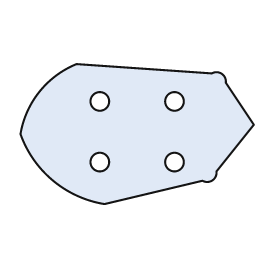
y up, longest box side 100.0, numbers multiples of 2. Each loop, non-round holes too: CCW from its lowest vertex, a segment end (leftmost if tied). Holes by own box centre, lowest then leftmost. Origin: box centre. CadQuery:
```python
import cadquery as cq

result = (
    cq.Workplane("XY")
    .moveTo(-14.0, -30.0)
    .lineTo(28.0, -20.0)
    .threePointArc((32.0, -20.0), (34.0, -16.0))
    .lineTo(50.0, 4.0)
    .lineTo(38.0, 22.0)
    .threePointArc((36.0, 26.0), (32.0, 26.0))
    .lineTo(-26.0, 30.0)
    .threePointArc((-42.0, 18.0), (-50.0, 0.0))
    .threePointArc((-36.0, -20.0), (-14.0, -30.0))
    .close()
    .moveTo(-16.0, -12.0)
    .circle(4.0)
    .moveTo(16.0, -12.0)
    .circle(4.0)
    .moveTo(-16.0, 14.0)
    .circle(4.0)
    .moveTo(16.0, 14.0)
    .circle(4.0)
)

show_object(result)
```